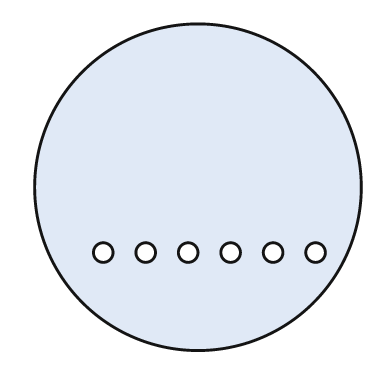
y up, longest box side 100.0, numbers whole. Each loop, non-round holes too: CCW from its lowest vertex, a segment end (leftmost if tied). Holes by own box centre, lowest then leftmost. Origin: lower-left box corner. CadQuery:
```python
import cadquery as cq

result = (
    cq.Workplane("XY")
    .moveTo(50.0, 50.0)
    .circle(50.0)
    .moveTo(21.0, 30.0)
    .circle(3.0)
    .moveTo(34.0, 30.0)
    .circle(3.0)
    .moveTo(47.0, 30.0)
    .circle(3.0)
    .moveTo(60.0, 30.0)
    .circle(3.0)
    .moveTo(73.0, 30.0)
    .circle(3.0)
    .moveTo(86.0, 30.0)
    .circle(3.0)
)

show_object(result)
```